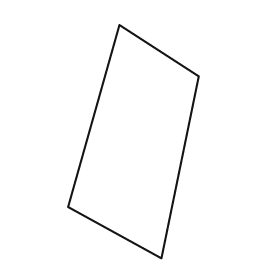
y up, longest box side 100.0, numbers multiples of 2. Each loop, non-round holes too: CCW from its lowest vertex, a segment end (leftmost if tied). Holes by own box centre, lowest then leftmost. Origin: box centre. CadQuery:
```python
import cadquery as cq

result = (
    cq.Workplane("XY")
    .moveTo(12.0, -50.0)
    .lineTo(28.0, 28.0)
    .lineTo(-6.0, 50.0)
    .lineTo(-28.0, -28.0)
    .close()
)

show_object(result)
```